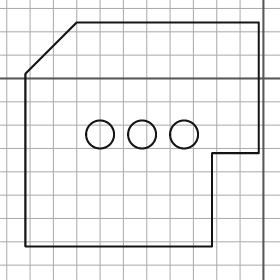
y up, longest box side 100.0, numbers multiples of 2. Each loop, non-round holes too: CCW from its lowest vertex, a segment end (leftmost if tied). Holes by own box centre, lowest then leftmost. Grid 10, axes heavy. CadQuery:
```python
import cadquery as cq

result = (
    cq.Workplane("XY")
    .moveTo(-102.0, -72.0)
    .lineTo(-22.0, -72.0)
    .lineTo(-22.0, -32.0)
    .lineTo(-2.0, -32.0)
    .lineTo(-2.0, 24.0)
    .lineTo(-80.0, 24.0)
    .lineTo(-102.0, 2.0)
    .close()
    .moveTo(-70.0, -24.0)
    .circle(6.0)
    .moveTo(-52.0, -24.0)
    .circle(6.0)
    .moveTo(-34.0, -24.0)
    .circle(6.0)
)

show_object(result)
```